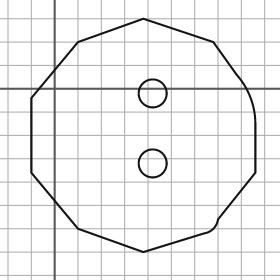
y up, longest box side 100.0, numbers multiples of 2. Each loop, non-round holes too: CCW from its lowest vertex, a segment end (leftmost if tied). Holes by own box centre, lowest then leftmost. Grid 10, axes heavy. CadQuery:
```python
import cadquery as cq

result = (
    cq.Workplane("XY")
    .moveTo(38.0, -70.0)
    .lineTo(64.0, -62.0)
    .threePointArc((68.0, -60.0), (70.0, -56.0))
    .lineTo(86.0, -36.0)
    .lineTo(86.0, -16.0)
    .threePointArc((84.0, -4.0), (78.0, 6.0))
    .lineTo(68.0, 20.0)
    .lineTo(38.0, 30.0)
    .lineTo(10.0, 20.0)
    .lineTo(-10.0, -4.0)
    .lineTo(-10.0, -36.0)
    .lineTo(10.0, -60.0)
    .close()
    .moveTo(42.0, -32.0)
    .circle(6.0)
    .moveTo(42.0, -2.0)
    .circle(6.0)
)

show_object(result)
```